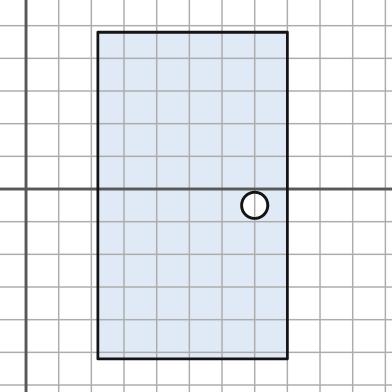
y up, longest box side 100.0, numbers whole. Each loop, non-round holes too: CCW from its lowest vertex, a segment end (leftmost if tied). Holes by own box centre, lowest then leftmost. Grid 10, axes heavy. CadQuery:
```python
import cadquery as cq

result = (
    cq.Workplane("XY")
    .moveTo(22.0, -52.0)
    .lineTo(80.0, -52.0)
    .lineTo(80.0, 48.0)
    .lineTo(22.0, 48.0)
    .close()
    .moveTo(70.0, -5.0)
    .circle(4.0)
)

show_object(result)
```